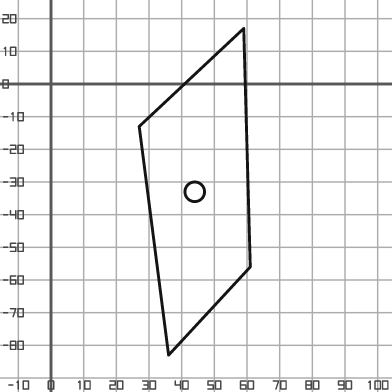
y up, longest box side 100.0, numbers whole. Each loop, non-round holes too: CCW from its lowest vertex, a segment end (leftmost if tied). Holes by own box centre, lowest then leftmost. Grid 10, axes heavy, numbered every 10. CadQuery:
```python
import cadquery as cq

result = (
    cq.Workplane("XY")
    .moveTo(36.0, -83.0)
    .lineTo(61.0, -56.0)
    .lineTo(59.0, 17.0)
    .lineTo(27.0, -13.0)
    .close()
    .moveTo(44.0, -33.0)
    .circle(3.0)
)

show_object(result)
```